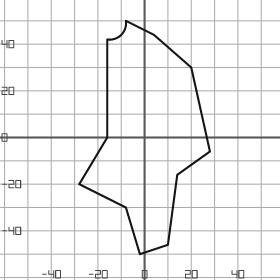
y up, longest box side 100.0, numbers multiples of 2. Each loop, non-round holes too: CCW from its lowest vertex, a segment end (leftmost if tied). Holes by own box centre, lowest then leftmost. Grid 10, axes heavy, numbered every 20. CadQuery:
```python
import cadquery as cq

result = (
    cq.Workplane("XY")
    .moveTo(-2.0, -50.0)
    .lineTo(10.0, -46.0)
    .lineTo(14.0, -16.0)
    .lineTo(28.0, -6.0)
    .lineTo(20.0, 30.0)
    .lineTo(4.0, 44.0)
    .lineTo(-8.0, 50.0)
    .threePointArc((-10.0, 44.0), (-16.0, 42.0))
    .lineTo(-16.0, 0.0)
    .lineTo(-28.0, -20.0)
    .lineTo(-8.0, -30.0)
    .close()
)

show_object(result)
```